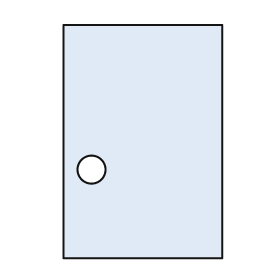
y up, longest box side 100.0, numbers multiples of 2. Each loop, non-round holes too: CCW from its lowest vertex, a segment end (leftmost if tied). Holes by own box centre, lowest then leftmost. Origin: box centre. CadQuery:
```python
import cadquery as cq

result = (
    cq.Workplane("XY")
    .moveTo(-34.0, -50.0)
    .lineTo(34.0, -50.0)
    .lineTo(34.0, 50.0)
    .lineTo(-34.0, 50.0)
    .close()
    .moveTo(-22.0, -12.0)
    .circle(6.0)
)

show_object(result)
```